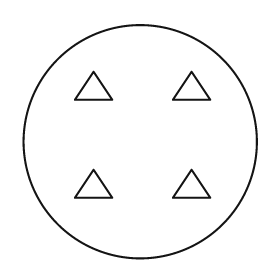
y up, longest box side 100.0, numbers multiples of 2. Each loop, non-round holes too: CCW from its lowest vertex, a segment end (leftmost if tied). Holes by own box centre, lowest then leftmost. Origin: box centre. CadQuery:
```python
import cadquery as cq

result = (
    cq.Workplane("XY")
    .moveTo(0.0, 0.0)
    .circle(50.0)
    .moveTo(-28.0, -24.0)
    .lineTo(-12.0, -24.0)
    .lineTo(-20.0, -12.0)
    .close()
    .moveTo(14.0, -24.0)
    .lineTo(30.0, -24.0)
    .lineTo(22.0, -12.0)
    .close()
    .moveTo(-28.0, 18.0)
    .lineTo(-12.0, 18.0)
    .lineTo(-20.0, 30.0)
    .close()
    .moveTo(14.0, 18.0)
    .lineTo(30.0, 18.0)
    .lineTo(22.0, 30.0)
    .close()
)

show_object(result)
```